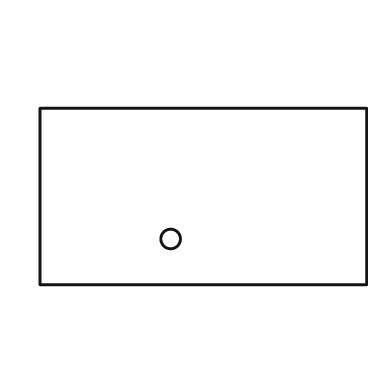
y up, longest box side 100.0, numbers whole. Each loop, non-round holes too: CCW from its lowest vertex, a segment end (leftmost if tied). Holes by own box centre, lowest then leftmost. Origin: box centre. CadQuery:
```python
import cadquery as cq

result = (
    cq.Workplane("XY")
    .moveTo(-50.0, -27.0)
    .lineTo(50.0, -27.0)
    .lineTo(50.0, 27.0)
    .lineTo(-50.0, 27.0)
    .close()
    .moveTo(-10.0, -13.0)
    .circle(3.0)
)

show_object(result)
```